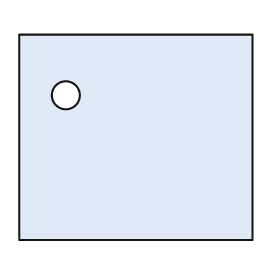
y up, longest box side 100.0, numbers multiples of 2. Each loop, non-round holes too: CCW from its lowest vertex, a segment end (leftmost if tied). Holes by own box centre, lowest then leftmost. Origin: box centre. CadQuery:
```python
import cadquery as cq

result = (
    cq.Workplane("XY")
    .moveTo(-50.0, -44.0)
    .lineTo(50.0, -44.0)
    .lineTo(50.0, 44.0)
    .lineTo(-50.0, 44.0)
    .close()
    .moveTo(-30.0, 18.0)
    .circle(6.0)
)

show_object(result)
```